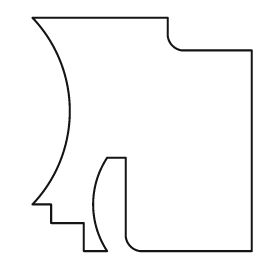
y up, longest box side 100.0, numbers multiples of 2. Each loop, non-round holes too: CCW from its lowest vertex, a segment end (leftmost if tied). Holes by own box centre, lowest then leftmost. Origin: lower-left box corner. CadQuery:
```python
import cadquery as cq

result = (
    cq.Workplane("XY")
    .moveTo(22.0, 0.0)
    .lineTo(32.0, 0.0)
    .threePointArc((26.0, 20.0), (32.0, 40.0))
    .lineTo(40.0, 40.0)
    .lineTo(40.0, 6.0)
    .threePointArc((42.0, 2.0), (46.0, 0.0))
    .lineTo(94.0, 0.0)
    .lineTo(94.0, 86.0)
    .lineTo(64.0, 86.0)
    .threePointArc((60.0, 88.0), (58.0, 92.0))
    .lineTo(58.0, 100.0)
    .lineTo(0.0, 100.0)
    .threePointArc((16.0, 60.0), (0.0, 20.0))
    .lineTo(8.0, 20.0)
    .lineTo(8.0, 12.0)
    .lineTo(22.0, 12.0)
    .close()
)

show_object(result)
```